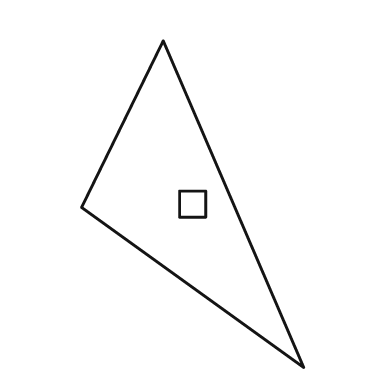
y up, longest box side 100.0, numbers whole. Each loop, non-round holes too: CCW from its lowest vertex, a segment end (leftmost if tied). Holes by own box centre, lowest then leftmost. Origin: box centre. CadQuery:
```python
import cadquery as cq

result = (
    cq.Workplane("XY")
    .moveTo(34.0, -50.0)
    .lineTo(-9.0, 50.0)
    .lineTo(-34.0, -1.0)
    .close()
    .moveTo(-4.0, -4.0)
    .lineTo(4.0, -4.0)
    .lineTo(4.0, 4.0)
    .lineTo(-4.0, 4.0)
    .close()
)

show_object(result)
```